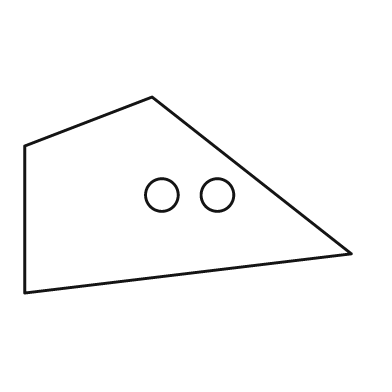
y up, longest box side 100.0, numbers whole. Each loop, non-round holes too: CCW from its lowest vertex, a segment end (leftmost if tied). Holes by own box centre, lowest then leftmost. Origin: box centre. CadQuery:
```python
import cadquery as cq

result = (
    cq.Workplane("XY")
    .moveTo(-50.0, -30.0)
    .lineTo(50.0, -18.0)
    .lineTo(-11.0, 30.0)
    .lineTo(-50.0, 15.0)
    .close()
    .moveTo(-8.0, 0.0)
    .circle(5.0)
    .moveTo(9.0, 0.0)
    .circle(5.0)
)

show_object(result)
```